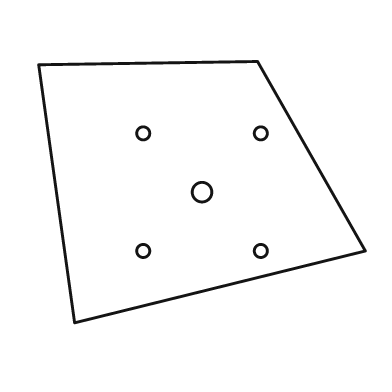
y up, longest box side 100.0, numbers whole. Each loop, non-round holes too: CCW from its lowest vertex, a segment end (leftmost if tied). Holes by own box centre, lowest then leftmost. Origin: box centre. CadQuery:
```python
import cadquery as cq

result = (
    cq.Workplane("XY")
    .moveTo(-39.0, -40.0)
    .lineTo(50.0, -18.0)
    .lineTo(17.0, 40.0)
    .lineTo(-50.0, 39.0)
    .close()
    .moveTo(-18.0, -18.0)
    .circle(2.0)
    .moveTo(18.0, -18.0)
    .circle(2.0)
    .moveTo(0.0, 0.0)
    .circle(3.0)
    .moveTo(-18.0, 18.0)
    .circle(2.0)
    .moveTo(18.0, 18.0)
    .circle(2.0)
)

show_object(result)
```